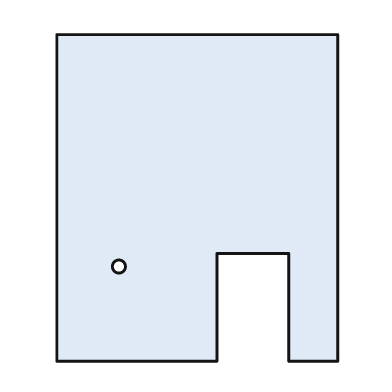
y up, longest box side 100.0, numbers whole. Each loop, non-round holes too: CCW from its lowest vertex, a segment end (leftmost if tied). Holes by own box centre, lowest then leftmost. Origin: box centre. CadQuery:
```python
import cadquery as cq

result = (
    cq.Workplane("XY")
    .moveTo(-43.0, -50.0)
    .lineTo(6.0, -50.0)
    .lineTo(6.0, -17.0)
    .lineTo(28.0, -17.0)
    .lineTo(28.0, -50.0)
    .lineTo(43.0, -50.0)
    .lineTo(43.0, 50.0)
    .lineTo(-43.0, 50.0)
    .close()
    .moveTo(-24.0, -21.0)
    .circle(2.0)
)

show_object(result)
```